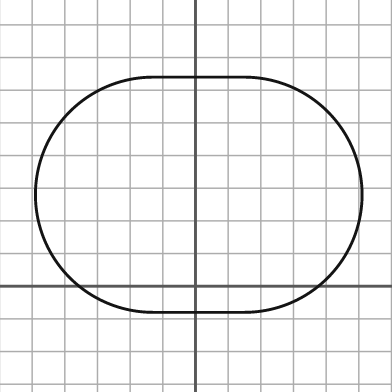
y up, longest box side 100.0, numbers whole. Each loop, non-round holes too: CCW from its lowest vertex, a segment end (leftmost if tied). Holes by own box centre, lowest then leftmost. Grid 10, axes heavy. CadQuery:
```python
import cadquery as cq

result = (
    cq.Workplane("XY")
    .moveTo(-13.0, -8.0)
    .lineTo(15.0, -8.0)
    .threePointArc((51.0, 28.0), (15.0, 64.0))
    .lineTo(-13.0, 64.0)
    .threePointArc((-49.0, 28.0), (-13.0, -8.0))
    .close()
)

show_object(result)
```